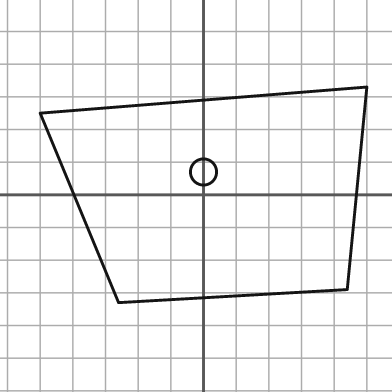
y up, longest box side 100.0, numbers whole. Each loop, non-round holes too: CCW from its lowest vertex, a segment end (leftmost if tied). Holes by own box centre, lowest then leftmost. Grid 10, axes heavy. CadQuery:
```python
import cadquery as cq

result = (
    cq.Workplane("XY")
    .moveTo(-26.0, -33.0)
    .lineTo(44.0, -29.0)
    .lineTo(50.0, 33.0)
    .lineTo(-50.0, 25.0)
    .close()
    .moveTo(0.0, 7.0)
    .circle(4.0)
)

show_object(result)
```